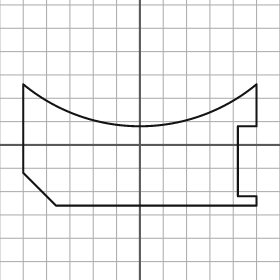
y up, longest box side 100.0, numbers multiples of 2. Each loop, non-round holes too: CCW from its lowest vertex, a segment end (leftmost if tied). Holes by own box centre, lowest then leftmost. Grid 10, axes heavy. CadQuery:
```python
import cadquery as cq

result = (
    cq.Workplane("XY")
    .moveTo(-36.0, -26.0)
    .lineTo(50.0, -26.0)
    .lineTo(50.0, -22.0)
    .lineTo(42.0, -22.0)
    .lineTo(42.0, 8.0)
    .lineTo(50.0, 8.0)
    .lineTo(50.0, 26.0)
    .threePointArc((0.0, 8.0), (-50.0, 26.0))
    .lineTo(-50.0, -12.0)
    .close()
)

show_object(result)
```